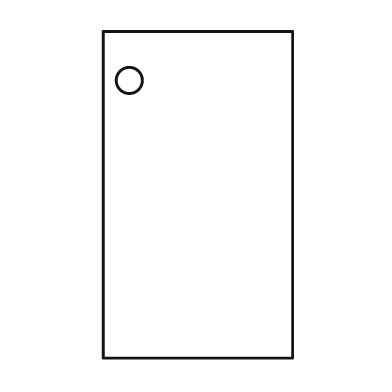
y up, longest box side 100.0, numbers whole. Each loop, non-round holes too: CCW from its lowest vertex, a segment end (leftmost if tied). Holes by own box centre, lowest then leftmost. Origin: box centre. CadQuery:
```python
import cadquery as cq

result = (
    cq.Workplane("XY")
    .moveTo(-29.0, -50.0)
    .lineTo(29.0, -50.0)
    .lineTo(29.0, 50.0)
    .lineTo(-29.0, 50.0)
    .close()
    .moveTo(-21.0, 35.0)
    .circle(4.0)
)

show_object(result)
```